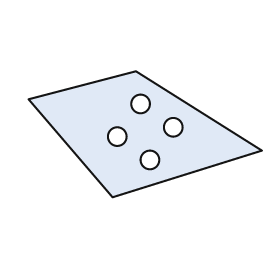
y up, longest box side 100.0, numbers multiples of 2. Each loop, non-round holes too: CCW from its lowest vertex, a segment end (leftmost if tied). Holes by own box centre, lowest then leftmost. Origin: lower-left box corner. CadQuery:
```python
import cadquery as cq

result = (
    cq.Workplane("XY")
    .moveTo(36.0, 0.0)
    .lineTo(100.0, 20.0)
    .lineTo(46.0, 54.0)
    .lineTo(0.0, 42.0)
    .close()
    .moveTo(52.0, 16.0)
    .circle(4.0)
    .moveTo(38.0, 26.0)
    .circle(4.0)
    .moveTo(62.0, 30.0)
    .circle(4.0)
    .moveTo(48.0, 40.0)
    .circle(4.0)
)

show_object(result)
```